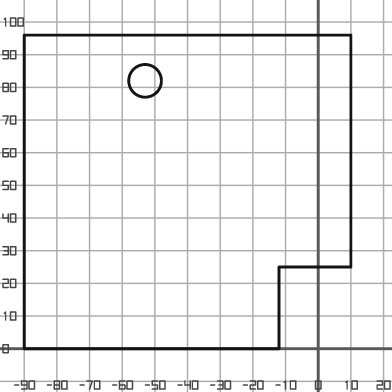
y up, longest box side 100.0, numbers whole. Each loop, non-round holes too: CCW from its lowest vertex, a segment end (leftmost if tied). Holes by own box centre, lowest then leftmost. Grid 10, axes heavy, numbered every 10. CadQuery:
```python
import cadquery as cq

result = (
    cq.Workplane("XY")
    .moveTo(-90.0, 0.0)
    .lineTo(-12.0, 0.0)
    .lineTo(-12.0, 25.0)
    .lineTo(10.0, 25.0)
    .lineTo(10.0, 96.0)
    .lineTo(-90.0, 96.0)
    .close()
    .moveTo(-53.0, 82.0)
    .circle(5.0)
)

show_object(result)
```